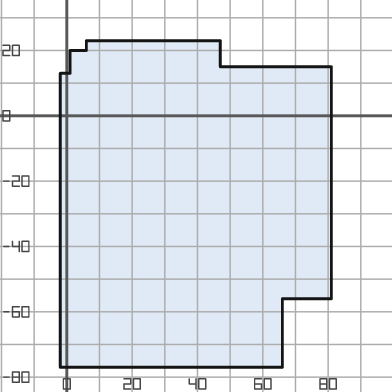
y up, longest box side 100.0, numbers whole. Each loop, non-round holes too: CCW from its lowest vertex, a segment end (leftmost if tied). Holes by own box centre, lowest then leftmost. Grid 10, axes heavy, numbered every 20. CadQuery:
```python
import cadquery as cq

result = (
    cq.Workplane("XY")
    .moveTo(-2.0, -77.0)
    .lineTo(66.0, -77.0)
    .lineTo(66.0, -56.0)
    .lineTo(81.0, -56.0)
    .lineTo(81.0, 15.0)
    .lineTo(47.0, 15.0)
    .lineTo(47.0, 23.0)
    .lineTo(6.0, 23.0)
    .lineTo(6.0, 20.0)
    .lineTo(1.0, 20.0)
    .lineTo(1.0, 13.0)
    .lineTo(-2.0, 13.0)
    .close()
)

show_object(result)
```